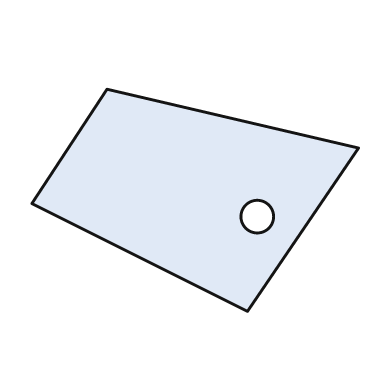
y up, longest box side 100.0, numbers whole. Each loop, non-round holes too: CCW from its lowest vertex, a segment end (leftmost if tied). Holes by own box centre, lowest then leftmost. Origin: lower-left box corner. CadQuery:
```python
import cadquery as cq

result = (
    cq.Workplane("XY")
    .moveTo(66.0, 0.0)
    .lineTo(100.0, 50.0)
    .lineTo(23.0, 68.0)
    .lineTo(0.0, 33.0)
    .close()
    .moveTo(69.0, 29.0)
    .circle(5.0)
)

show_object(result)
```